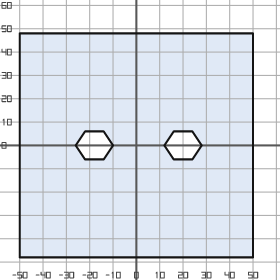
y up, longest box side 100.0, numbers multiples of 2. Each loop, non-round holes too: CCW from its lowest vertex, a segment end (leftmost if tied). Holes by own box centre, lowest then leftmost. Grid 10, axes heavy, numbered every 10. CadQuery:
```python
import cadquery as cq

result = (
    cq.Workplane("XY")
    .moveTo(-50.0, -48.0)
    .lineTo(50.0, -48.0)
    .lineTo(50.0, 48.0)
    .lineTo(-50.0, 48.0)
    .close()
    .moveTo(-22.0, -6.0)
    .lineTo(-14.0, -6.0)
    .lineTo(-10.0, 0.0)
    .lineTo(-14.0, 6.0)
    .lineTo(-22.0, 6.0)
    .lineTo(-26.0, 0.0)
    .close()
    .moveTo(16.0, -6.0)
    .lineTo(24.0, -6.0)
    .lineTo(28.0, 0.0)
    .lineTo(24.0, 6.0)
    .lineTo(16.0, 6.0)
    .lineTo(12.0, 0.0)
    .close()
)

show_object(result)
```